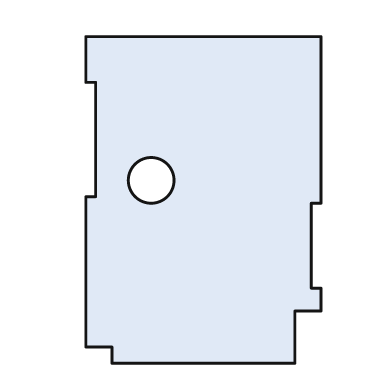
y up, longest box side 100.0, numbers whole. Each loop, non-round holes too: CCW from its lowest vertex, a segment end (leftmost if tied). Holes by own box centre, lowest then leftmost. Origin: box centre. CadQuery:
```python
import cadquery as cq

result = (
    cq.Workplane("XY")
    .moveTo(-28.0, -50.0)
    .lineTo(28.0, -50.0)
    .lineTo(28.0, -34.0)
    .lineTo(36.0, -34.0)
    .lineTo(36.0, -27.0)
    .lineTo(33.0, -27.0)
    .lineTo(33.0, -1.0)
    .lineTo(36.0, -1.0)
    .lineTo(36.0, 50.0)
    .lineTo(-36.0, 50.0)
    .lineTo(-36.0, 36.0)
    .lineTo(-33.0, 36.0)
    .lineTo(-33.0, 1.0)
    .lineTo(-36.0, 1.0)
    .lineTo(-36.0, -45.0)
    .lineTo(-28.0, -45.0)
    .close()
    .moveTo(-16.0, 6.0)
    .circle(7.0)
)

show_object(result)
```